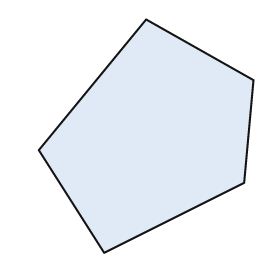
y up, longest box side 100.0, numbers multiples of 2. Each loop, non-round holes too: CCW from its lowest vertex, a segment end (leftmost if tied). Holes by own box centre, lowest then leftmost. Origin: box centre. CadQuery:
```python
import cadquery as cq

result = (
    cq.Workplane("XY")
    .moveTo(-18.0, -50.0)
    .lineTo(42.0, -20.0)
    .lineTo(46.0, 24.0)
    .lineTo(0.0, 50.0)
    .lineTo(-46.0, -6.0)
    .close()
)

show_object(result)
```